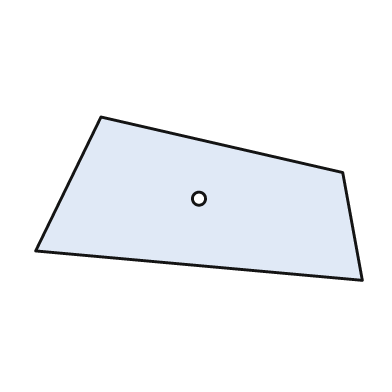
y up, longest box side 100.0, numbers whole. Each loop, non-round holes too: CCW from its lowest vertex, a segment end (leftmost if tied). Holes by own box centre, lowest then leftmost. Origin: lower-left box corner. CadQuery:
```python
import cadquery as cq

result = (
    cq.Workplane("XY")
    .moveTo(100.0, 0.0)
    .lineTo(94.0, 33.0)
    .lineTo(20.0, 50.0)
    .lineTo(0.0, 9.0)
    .close()
    .moveTo(50.0, 25.0)
    .circle(2.0)
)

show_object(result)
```